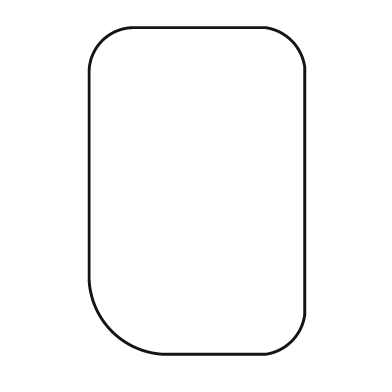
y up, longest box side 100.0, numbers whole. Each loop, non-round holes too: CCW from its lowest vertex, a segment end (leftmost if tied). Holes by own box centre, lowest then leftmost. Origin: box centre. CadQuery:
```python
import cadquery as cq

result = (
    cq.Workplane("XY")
    .moveTo(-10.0, -50.0)
    .lineTo(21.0, -50.0)
    .threePointArc((29.0, -46.0), (33.0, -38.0))
    .lineTo(33.0, 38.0)
    .threePointArc((29.0, 46.0), (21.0, 50.0))
    .lineTo(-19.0, 50.0)
    .threePointArc((-29.0, 46.0), (-33.0, 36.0))
    .lineTo(-33.0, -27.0)
    .threePointArc((-26.0, -43.0), (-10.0, -50.0))
    .close()
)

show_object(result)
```